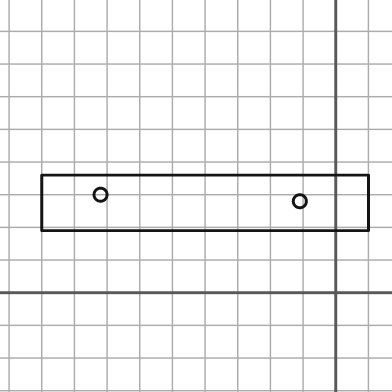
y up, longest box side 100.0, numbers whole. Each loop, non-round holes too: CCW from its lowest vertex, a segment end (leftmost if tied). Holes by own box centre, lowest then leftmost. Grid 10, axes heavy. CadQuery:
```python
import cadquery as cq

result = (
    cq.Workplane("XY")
    .moveTo(-90.0, 19.0)
    .lineTo(10.0, 19.0)
    .lineTo(10.0, 36.0)
    .lineTo(-90.0, 36.0)
    .close()
    .moveTo(-11.0, 28.0)
    .circle(2.0)
    .moveTo(-72.0, 30.0)
    .circle(2.0)
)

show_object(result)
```